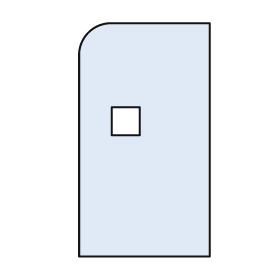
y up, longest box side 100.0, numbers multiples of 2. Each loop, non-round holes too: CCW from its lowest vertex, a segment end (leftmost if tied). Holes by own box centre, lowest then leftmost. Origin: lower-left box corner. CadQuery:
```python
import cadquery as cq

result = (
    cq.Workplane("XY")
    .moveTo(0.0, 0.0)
    .lineTo(56.0, 0.0)
    .lineTo(56.0, 100.0)
    .lineTo(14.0, 100.0)
    .threePointArc((4.0, 96.0), (0.0, 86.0))
    .close()
    .moveTo(14.0, 52.0)
    .lineTo(26.0, 52.0)
    .lineTo(26.0, 64.0)
    .lineTo(14.0, 64.0)
    .close()
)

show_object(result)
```